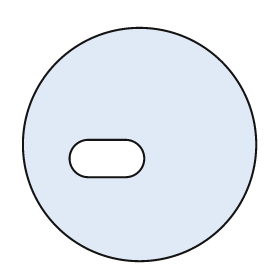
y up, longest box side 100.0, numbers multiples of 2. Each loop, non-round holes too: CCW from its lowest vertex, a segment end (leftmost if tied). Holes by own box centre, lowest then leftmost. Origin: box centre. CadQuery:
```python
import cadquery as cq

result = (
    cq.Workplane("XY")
    .moveTo(0.0, 0.0)
    .circle(50.0)
    .moveTo(-22.0, -14.0)
    .lineTo(-6.0, -14.0)
    .threePointArc((2.0, -6.0), (-6.0, 2.0))
    .lineTo(-22.0, 2.0)
    .threePointArc((-30.0, -6.0), (-22.0, -14.0))
    .close()
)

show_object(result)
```